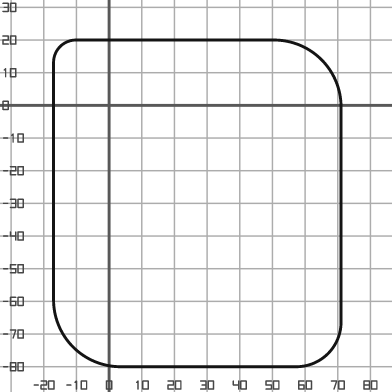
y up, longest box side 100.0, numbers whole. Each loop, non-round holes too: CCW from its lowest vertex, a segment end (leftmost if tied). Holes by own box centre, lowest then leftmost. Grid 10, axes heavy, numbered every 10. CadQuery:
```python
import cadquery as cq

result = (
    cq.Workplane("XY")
    .moveTo(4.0, -80.0)
    .lineTo(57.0, -80.0)
    .threePointArc((67.0, -76.0), (71.0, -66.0))
    .lineTo(71.0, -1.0)
    .threePointArc((65.0, 14.0), (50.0, 20.0))
    .lineTo(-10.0, 20.0)
    .threePointArc((-15.0, 18.0), (-17.0, 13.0))
    .lineTo(-17.0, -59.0)
    .threePointArc((-11.0, -74.0), (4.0, -80.0))
    .close()
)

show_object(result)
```